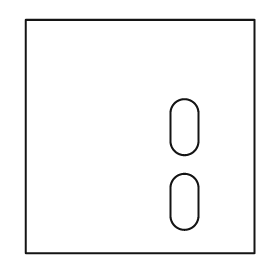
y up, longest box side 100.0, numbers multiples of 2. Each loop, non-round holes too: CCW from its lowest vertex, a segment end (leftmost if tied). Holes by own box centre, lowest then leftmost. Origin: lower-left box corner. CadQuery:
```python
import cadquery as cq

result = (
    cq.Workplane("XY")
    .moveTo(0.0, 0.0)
    .lineTo(98.0, 0.0)
    .lineTo(98.0, 100.0)
    .lineTo(0.0, 100.0)
    .close()
    .moveTo(62.0, 16.0)
    .threePointArc((68.0, 10.0), (74.0, 16.0))
    .lineTo(74.0, 28.0)
    .threePointArc((68.0, 34.0), (62.0, 28.0))
    .close()
    .moveTo(62.0, 48.0)
    .threePointArc((68.0, 42.0), (74.0, 48.0))
    .lineTo(74.0, 60.0)
    .threePointArc((68.0, 66.0), (62.0, 60.0))
    .close()
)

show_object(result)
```